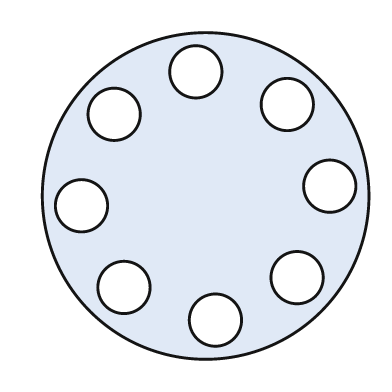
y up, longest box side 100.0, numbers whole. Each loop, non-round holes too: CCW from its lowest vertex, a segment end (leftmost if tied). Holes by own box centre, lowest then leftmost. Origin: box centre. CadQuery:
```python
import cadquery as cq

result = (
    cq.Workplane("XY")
    .moveTo(0.0, 0.0)
    .circle(50.0)
    .moveTo(3.0, -38.0)
    .circle(8.0)
    .moveTo(-25.0, -28.0)
    .circle(8.0)
    .moveTo(28.0, -25.0)
    .circle(8.0)
    .moveTo(-38.0, -3.0)
    .circle(8.0)
    .moveTo(38.0, 3.0)
    .circle(8.0)
    .moveTo(-28.0, 25.0)
    .circle(8.0)
    .moveTo(25.0, 28.0)
    .circle(8.0)
    .moveTo(-3.0, 38.0)
    .circle(8.0)
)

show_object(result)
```